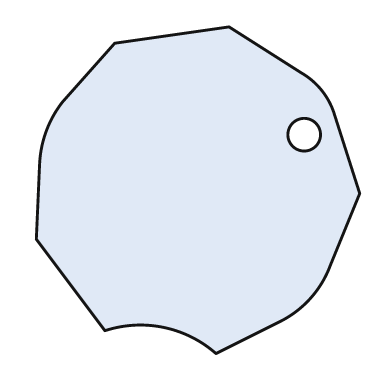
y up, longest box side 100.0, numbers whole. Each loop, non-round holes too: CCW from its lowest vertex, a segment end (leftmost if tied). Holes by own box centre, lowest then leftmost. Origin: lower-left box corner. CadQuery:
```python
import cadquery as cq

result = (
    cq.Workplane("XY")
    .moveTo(55.0, 0.0)
    .lineTo(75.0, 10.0)
    .threePointArc((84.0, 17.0), (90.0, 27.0))
    .lineTo(99.0, 49.0)
    .lineTo(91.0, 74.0)
    .threePointArc((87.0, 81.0), (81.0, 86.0))
    .lineTo(59.0, 100.0)
    .lineTo(24.0, 95.0)
    .lineTo(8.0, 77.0)
    .threePointArc((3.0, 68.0), (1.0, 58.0))
    .lineTo(0.0, 35.0)
    .lineTo(21.0, 7.0)
    .threePointArc((39.0, 8.0), (55.0, 0.0))
    .close()
    .moveTo(82.0, 67.0)
    .circle(5.0)
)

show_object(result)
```